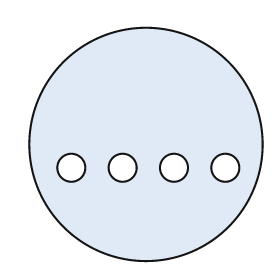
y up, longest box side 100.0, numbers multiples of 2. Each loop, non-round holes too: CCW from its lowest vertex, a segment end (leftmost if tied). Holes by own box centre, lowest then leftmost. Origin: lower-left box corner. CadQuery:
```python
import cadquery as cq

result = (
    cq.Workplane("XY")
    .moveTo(50.0, 50.0)
    .circle(50.0)
    .moveTo(18.0, 40.0)
    .circle(6.0)
    .moveTo(40.0, 40.0)
    .circle(6.0)
    .moveTo(62.0, 40.0)
    .circle(6.0)
    .moveTo(84.0, 40.0)
    .circle(6.0)
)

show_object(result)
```